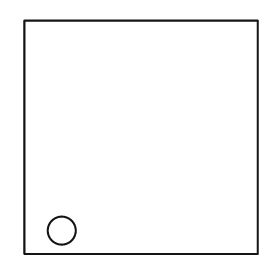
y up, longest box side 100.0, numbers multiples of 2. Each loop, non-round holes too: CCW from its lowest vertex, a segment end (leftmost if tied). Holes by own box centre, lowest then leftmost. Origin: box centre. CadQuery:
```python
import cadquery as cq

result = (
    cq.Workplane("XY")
    .moveTo(-50.0, -50.0)
    .lineTo(50.0, -50.0)
    .lineTo(50.0, 50.0)
    .lineTo(-50.0, 50.0)
    .close()
    .moveTo(-34.0, -40.0)
    .circle(6.0)
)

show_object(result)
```